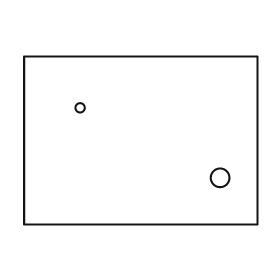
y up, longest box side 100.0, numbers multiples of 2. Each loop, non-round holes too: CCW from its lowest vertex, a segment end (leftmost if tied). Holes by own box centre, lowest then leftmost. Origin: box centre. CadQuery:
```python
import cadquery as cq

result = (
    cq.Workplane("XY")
    .moveTo(-50.0, -36.0)
    .lineTo(50.0, -36.0)
    .lineTo(50.0, 36.0)
    .lineTo(-50.0, 36.0)
    .close()
    .moveTo(34.0, -16.0)
    .circle(4.0)
    .moveTo(-26.0, 14.0)
    .circle(2.0)
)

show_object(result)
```